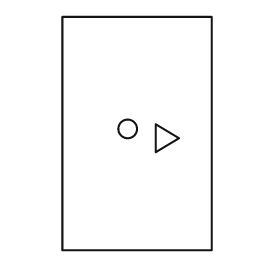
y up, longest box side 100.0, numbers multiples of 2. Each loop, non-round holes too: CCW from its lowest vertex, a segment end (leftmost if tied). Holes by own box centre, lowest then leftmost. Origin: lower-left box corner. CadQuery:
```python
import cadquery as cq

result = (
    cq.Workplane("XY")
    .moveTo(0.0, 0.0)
    .lineTo(64.0, 0.0)
    .lineTo(64.0, 100.0)
    .lineTo(0.0, 100.0)
    .close()
    .moveTo(40.0, 42.0)
    .lineTo(50.0, 48.0)
    .lineTo(40.0, 54.0)
    .close()
    .moveTo(28.0, 52.0)
    .circle(4.0)
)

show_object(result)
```